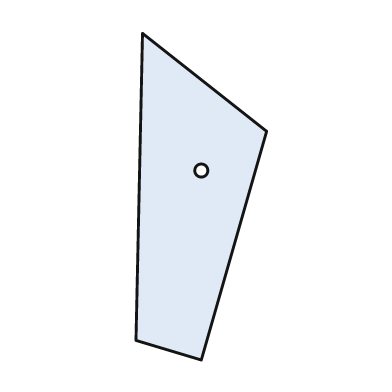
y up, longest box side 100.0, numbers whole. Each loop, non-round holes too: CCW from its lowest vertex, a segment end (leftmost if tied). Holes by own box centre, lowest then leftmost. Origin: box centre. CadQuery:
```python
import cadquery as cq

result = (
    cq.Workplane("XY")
    .moveTo(0.0, -50.0)
    .lineTo(20.0, 20.0)
    .lineTo(-18.0, 50.0)
    .lineTo(-20.0, -44.0)
    .close()
    .moveTo(0.0, 8.0)
    .circle(2.0)
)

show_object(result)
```